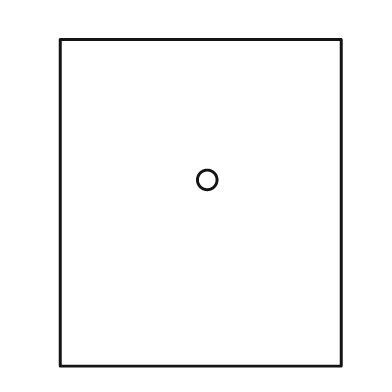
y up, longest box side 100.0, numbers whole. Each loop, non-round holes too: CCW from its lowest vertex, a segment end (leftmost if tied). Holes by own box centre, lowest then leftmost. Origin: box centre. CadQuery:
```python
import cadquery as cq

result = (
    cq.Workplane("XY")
    .moveTo(-43.0, -50.0)
    .lineTo(43.0, -50.0)
    .lineTo(43.0, 50.0)
    .lineTo(-43.0, 50.0)
    .close()
    .moveTo(2.0, 7.0)
    .circle(3.0)
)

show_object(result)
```